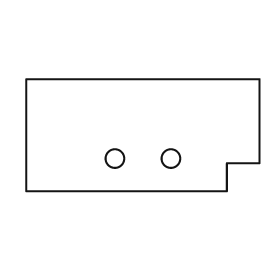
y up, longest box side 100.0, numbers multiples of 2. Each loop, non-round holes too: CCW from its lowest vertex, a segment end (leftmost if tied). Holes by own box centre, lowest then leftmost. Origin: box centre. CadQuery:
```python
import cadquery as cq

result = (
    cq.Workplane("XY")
    .moveTo(-50.0, -24.0)
    .lineTo(36.0, -24.0)
    .lineTo(36.0, -12.0)
    .lineTo(50.0, -12.0)
    .lineTo(50.0, 24.0)
    .lineTo(-50.0, 24.0)
    .close()
    .moveTo(-12.0, -10.0)
    .circle(4.0)
    .moveTo(12.0, -10.0)
    .circle(4.0)
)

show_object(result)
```